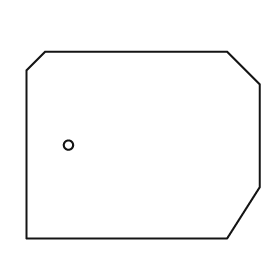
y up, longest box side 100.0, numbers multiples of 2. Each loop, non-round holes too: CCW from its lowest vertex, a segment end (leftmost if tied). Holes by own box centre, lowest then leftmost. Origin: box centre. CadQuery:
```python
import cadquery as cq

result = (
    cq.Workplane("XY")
    .moveTo(-50.0, -40.0)
    .lineTo(36.0, -40.0)
    .lineTo(50.0, -18.0)
    .lineTo(50.0, 26.0)
    .lineTo(36.0, 40.0)
    .lineTo(-42.0, 40.0)
    .lineTo(-50.0, 32.0)
    .close()
    .moveTo(-32.0, 0.0)
    .circle(2.0)
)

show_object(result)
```